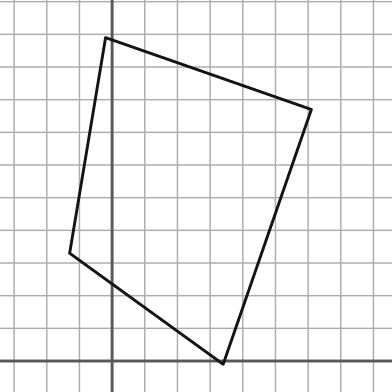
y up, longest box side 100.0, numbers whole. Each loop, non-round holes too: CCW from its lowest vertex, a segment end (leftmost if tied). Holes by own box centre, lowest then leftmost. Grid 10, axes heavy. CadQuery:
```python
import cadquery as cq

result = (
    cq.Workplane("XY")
    .moveTo(34.0, -1.0)
    .lineTo(61.0, 77.0)
    .lineTo(-2.0, 99.0)
    .lineTo(-13.0, 33.0)
    .close()
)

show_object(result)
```